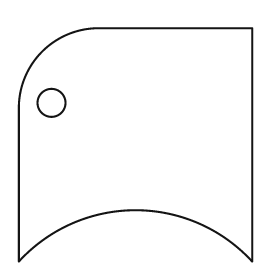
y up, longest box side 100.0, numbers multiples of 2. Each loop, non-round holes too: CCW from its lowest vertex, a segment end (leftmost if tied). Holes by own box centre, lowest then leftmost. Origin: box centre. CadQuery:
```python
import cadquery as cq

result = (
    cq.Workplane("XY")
    .moveTo(-50.0, -50.0)
    .threePointArc((0.0, -28.0), (50.0, -50.0))
    .lineTo(50.0, 50.0)
    .lineTo(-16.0, 50.0)
    .threePointArc((-40.0, 40.0), (-50.0, 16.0))
    .close()
    .moveTo(-36.0, 18.0)
    .circle(6.0)
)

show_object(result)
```